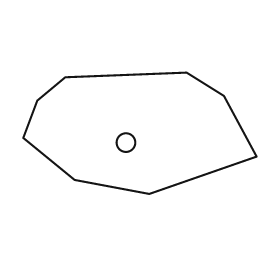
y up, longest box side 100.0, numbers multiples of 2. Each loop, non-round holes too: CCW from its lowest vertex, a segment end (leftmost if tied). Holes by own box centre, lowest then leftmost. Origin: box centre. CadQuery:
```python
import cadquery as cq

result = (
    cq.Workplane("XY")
    .moveTo(4.0, -26.0)
    .lineTo(50.0, -10.0)
    .lineTo(36.0, 16.0)
    .lineTo(20.0, 26.0)
    .lineTo(-32.0, 24.0)
    .lineTo(-44.0, 14.0)
    .lineTo(-50.0, -2.0)
    .lineTo(-28.0, -20.0)
    .close()
    .moveTo(-6.0, -4.0)
    .circle(4.0)
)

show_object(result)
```